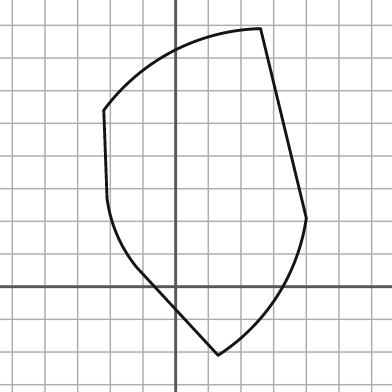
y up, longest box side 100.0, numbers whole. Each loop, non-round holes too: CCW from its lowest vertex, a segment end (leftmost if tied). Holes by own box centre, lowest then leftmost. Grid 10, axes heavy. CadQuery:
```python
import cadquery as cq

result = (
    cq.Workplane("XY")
    .moveTo(13.0, -21.0)
    .threePointArc((31.0, -3.0), (40.0, 21.0))
    .lineTo(26.0, 79.0)
    .threePointArc((-1.0, 72.0), (-22.0, 54.0))
    .lineTo(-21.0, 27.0)
    .threePointArc((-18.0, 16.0), (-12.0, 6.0))
    .close()
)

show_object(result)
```